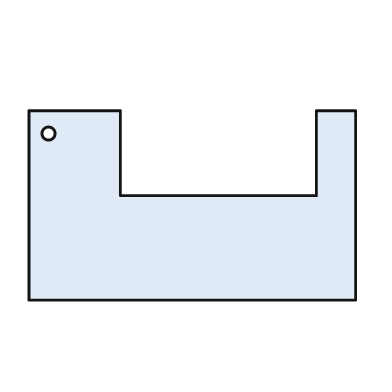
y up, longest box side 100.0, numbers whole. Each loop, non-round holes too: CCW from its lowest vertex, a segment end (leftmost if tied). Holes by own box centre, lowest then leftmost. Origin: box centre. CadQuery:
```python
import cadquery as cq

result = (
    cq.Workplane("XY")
    .moveTo(-50.0, -29.0)
    .lineTo(50.0, -29.0)
    .lineTo(50.0, 29.0)
    .lineTo(38.0, 29.0)
    .lineTo(38.0, 3.0)
    .lineTo(-22.0, 3.0)
    .lineTo(-22.0, 29.0)
    .lineTo(-50.0, 29.0)
    .close()
    .moveTo(-44.0, 22.0)
    .circle(2.0)
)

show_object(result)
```